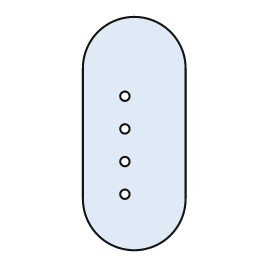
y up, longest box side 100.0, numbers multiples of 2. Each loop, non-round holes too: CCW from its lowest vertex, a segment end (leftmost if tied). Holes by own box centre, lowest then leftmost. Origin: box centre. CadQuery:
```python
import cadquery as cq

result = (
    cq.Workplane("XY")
    .moveTo(-22.0, -28.0)
    .threePointArc((0.0, -50.0), (22.0, -28.0))
    .lineTo(22.0, 28.0)
    .threePointArc((0.0, 50.0), (-22.0, 28.0))
    .close()
    .moveTo(-4.0, -26.0)
    .circle(2.0)
    .moveTo(-4.0, -12.0)
    .circle(2.0)
    .moveTo(-4.0, 2.0)
    .circle(2.0)
    .moveTo(-4.0, 16.0)
    .circle(2.0)
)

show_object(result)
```